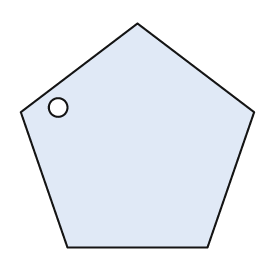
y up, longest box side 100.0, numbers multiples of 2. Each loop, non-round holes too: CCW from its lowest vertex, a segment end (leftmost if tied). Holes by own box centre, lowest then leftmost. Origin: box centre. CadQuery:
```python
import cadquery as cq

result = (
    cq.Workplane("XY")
    .moveTo(-30.0, -48.0)
    .lineTo(30.0, -48.0)
    .lineTo(50.0, 10.0)
    .lineTo(0.0, 48.0)
    .lineTo(-50.0, 10.0)
    .close()
    .moveTo(-34.0, 12.0)
    .circle(4.0)
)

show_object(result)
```